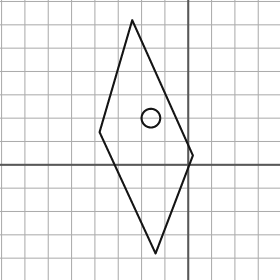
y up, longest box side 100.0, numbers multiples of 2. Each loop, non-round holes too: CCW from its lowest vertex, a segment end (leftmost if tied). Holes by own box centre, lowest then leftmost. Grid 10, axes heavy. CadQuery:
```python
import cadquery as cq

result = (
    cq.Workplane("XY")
    .moveTo(-14.0, -38.0)
    .lineTo(2.0, 4.0)
    .lineTo(-24.0, 62.0)
    .lineTo(-38.0, 14.0)
    .close()
    .moveTo(-16.0, 20.0)
    .circle(4.0)
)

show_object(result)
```